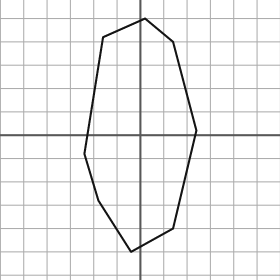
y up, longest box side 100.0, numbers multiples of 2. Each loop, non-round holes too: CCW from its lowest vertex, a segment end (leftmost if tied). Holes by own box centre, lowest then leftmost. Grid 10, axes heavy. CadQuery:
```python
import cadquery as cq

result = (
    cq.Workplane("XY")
    .moveTo(-4.0, -50.0)
    .lineTo(14.0, -40.0)
    .lineTo(24.0, 2.0)
    .lineTo(14.0, 40.0)
    .lineTo(2.0, 50.0)
    .lineTo(-16.0, 42.0)
    .lineTo(-24.0, -8.0)
    .lineTo(-18.0, -28.0)
    .close()
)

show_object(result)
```